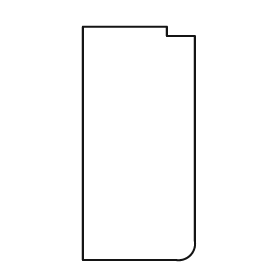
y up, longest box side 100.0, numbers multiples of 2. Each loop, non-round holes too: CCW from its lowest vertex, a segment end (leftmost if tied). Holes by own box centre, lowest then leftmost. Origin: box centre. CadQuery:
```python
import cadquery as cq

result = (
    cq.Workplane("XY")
    .moveTo(-24.0, -50.0)
    .lineTo(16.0, -50.0)
    .threePointArc((22.0, -48.0), (24.0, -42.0))
    .lineTo(24.0, 46.0)
    .lineTo(12.0, 46.0)
    .lineTo(12.0, 50.0)
    .lineTo(-24.0, 50.0)
    .close()
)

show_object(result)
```